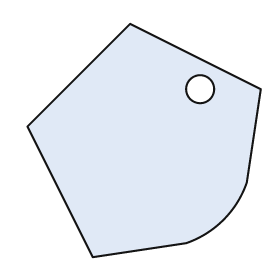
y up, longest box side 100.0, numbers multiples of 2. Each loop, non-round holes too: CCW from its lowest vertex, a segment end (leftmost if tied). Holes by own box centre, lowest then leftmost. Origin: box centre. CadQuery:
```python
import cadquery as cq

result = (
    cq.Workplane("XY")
    .moveTo(-22.0, -50.0)
    .lineTo(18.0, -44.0)
    .threePointArc((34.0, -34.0), (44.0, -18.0))
    .lineTo(50.0, 22.0)
    .lineTo(-6.0, 50.0)
    .lineTo(-50.0, 6.0)
    .close()
    .moveTo(24.0, 22.0)
    .circle(6.0)
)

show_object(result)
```